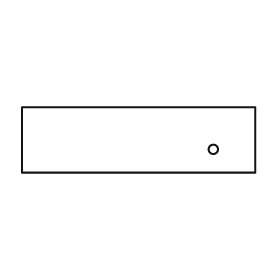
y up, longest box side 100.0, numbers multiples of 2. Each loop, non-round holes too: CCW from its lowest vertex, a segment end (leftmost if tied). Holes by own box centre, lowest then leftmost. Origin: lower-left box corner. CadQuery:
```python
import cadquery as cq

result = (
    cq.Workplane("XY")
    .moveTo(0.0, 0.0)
    .lineTo(100.0, 0.0)
    .lineTo(100.0, 28.0)
    .lineTo(0.0, 28.0)
    .close()
    .moveTo(82.0, 10.0)
    .circle(2.0)
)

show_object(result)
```